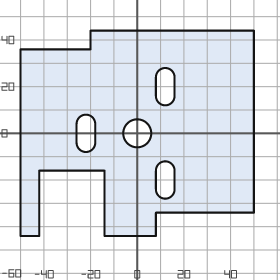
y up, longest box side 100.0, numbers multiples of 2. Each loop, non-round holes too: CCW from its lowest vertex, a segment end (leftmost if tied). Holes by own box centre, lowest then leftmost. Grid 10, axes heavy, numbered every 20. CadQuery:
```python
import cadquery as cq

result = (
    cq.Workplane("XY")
    .moveTo(-50.0, -44.0)
    .lineTo(-42.0, -44.0)
    .lineTo(-42.0, -16.0)
    .lineTo(-14.0, -16.0)
    .lineTo(-14.0, -44.0)
    .lineTo(8.0, -44.0)
    .lineTo(8.0, -34.0)
    .lineTo(50.0, -34.0)
    .lineTo(50.0, 44.0)
    .lineTo(-20.0, 44.0)
    .lineTo(-20.0, 36.0)
    .lineTo(-50.0, 36.0)
    .close()
    .moveTo(8.0, -24.0)
    .threePointArc((12.0, -28.0), (16.0, -24.0))
    .lineTo(16.0, -16.0)
    .threePointArc((12.0, -12.0), (8.0, -16.0))
    .close()
    .moveTo(-26.0, -4.0)
    .threePointArc((-22.0, -8.0), (-18.0, -4.0))
    .lineTo(-18.0, 4.0)
    .threePointArc((-22.0, 8.0), (-26.0, 4.0))
    .close()
    .moveTo(0.0, 0.0)
    .circle(6.0)
    .moveTo(8.0, 16.0)
    .threePointArc((12.0, 12.0), (16.0, 16.0))
    .lineTo(16.0, 24.0)
    .threePointArc((12.0, 28.0), (8.0, 24.0))
    .close()
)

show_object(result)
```